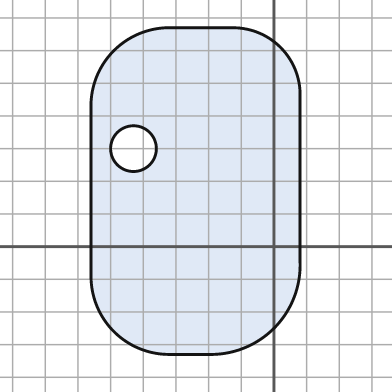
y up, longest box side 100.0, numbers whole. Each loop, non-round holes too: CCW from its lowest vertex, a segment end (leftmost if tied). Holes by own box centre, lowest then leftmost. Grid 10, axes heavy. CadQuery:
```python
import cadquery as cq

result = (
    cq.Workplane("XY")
    .moveTo(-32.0, -33.0)
    .lineTo(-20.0, -33.0)
    .threePointArc((0.0, -25.0), (8.0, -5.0))
    .lineTo(8.0, 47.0)
    .threePointArc((2.0, 61.0), (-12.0, 67.0))
    .lineTo(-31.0, 67.0)
    .threePointArc((-49.0, 60.0), (-56.0, 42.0))
    .lineTo(-56.0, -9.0)
    .threePointArc((-49.0, -26.0), (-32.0, -33.0))
    .close()
    .moveTo(-43.0, 30.0)
    .circle(7.0)
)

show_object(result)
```